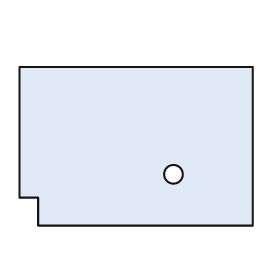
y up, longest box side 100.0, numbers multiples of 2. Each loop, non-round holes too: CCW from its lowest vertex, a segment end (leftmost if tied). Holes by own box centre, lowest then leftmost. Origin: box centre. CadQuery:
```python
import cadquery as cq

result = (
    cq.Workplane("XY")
    .moveTo(-42.0, -34.0)
    .lineTo(50.0, -34.0)
    .lineTo(50.0, 34.0)
    .lineTo(-50.0, 34.0)
    .lineTo(-50.0, -22.0)
    .lineTo(-42.0, -22.0)
    .close()
    .moveTo(16.0, -12.0)
    .circle(4.0)
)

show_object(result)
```